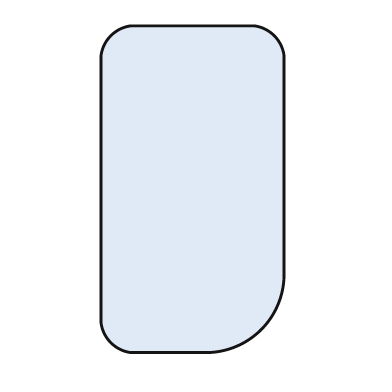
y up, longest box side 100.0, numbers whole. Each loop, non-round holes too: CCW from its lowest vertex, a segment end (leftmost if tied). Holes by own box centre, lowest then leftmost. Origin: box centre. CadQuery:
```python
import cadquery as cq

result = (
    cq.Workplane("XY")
    .moveTo(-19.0, -50.0)
    .lineTo(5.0, -50.0)
    .threePointArc((21.0, -43.0), (28.0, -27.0))
    .lineTo(28.0, 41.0)
    .threePointArc((25.0, 47.0), (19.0, 50.0))
    .lineTo(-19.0, 50.0)
    .threePointArc((-25.0, 47.0), (-28.0, 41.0))
    .lineTo(-28.0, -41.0)
    .threePointArc((-25.0, -47.0), (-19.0, -50.0))
    .close()
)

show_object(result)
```